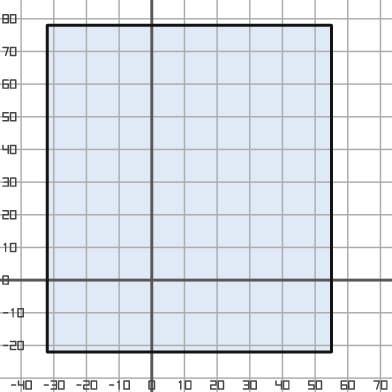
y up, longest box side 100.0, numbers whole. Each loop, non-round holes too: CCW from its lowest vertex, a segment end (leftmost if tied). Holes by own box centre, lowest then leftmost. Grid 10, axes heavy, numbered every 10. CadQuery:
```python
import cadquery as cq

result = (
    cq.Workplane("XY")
    .moveTo(-32.0, -22.0)
    .lineTo(55.0, -22.0)
    .lineTo(55.0, 78.0)
    .lineTo(-32.0, 78.0)
    .close()
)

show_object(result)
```